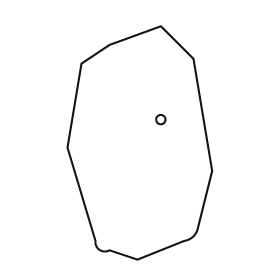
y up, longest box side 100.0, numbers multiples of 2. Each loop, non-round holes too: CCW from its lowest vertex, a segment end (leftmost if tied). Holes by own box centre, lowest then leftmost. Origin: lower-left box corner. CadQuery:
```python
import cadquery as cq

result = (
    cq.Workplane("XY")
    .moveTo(30.0, 0.0)
    .lineTo(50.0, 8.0)
    .threePointArc((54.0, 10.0), (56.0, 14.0))
    .lineTo(62.0, 38.0)
    .lineTo(54.0, 86.0)
    .lineTo(40.0, 100.0)
    .lineTo(18.0, 92.0)
    .lineTo(6.0, 84.0)
    .lineTo(0.0, 48.0)
    .lineTo(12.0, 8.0)
    .threePointArc((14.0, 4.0), (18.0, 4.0))
    .close()
    .moveTo(40.0, 60.0)
    .circle(2.0)
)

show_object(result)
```